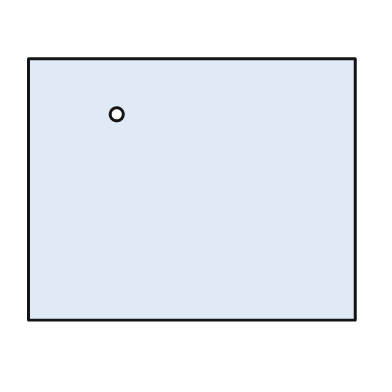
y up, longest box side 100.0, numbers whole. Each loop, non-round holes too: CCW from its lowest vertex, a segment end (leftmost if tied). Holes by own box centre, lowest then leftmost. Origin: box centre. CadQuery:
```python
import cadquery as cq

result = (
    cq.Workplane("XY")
    .moveTo(-50.0, -40.0)
    .lineTo(50.0, -40.0)
    .lineTo(50.0, 40.0)
    .lineTo(-50.0, 40.0)
    .close()
    .moveTo(-23.0, 23.0)
    .circle(2.0)
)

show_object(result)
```